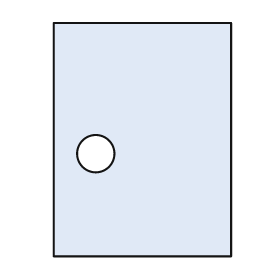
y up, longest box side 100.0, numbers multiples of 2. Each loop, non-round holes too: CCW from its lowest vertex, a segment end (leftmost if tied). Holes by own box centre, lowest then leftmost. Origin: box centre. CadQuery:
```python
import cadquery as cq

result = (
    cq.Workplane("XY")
    .moveTo(-38.0, -50.0)
    .lineTo(38.0, -50.0)
    .lineTo(38.0, 50.0)
    .lineTo(-38.0, 50.0)
    .close()
    .moveTo(-20.0, -6.0)
    .circle(8.0)
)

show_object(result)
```